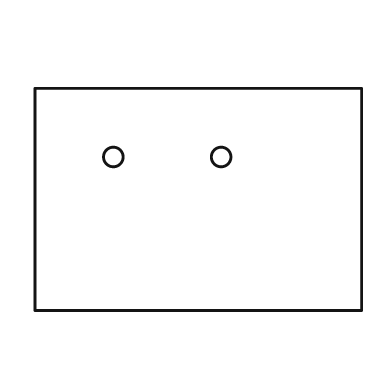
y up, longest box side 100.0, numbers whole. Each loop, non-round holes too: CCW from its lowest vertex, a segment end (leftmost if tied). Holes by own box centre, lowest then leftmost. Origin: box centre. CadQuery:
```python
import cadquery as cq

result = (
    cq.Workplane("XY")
    .moveTo(-50.0, -34.0)
    .lineTo(50.0, -34.0)
    .lineTo(50.0, 34.0)
    .lineTo(-50.0, 34.0)
    .close()
    .moveTo(-26.0, 13.0)
    .circle(3.0)
    .moveTo(7.0, 13.0)
    .circle(3.0)
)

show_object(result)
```